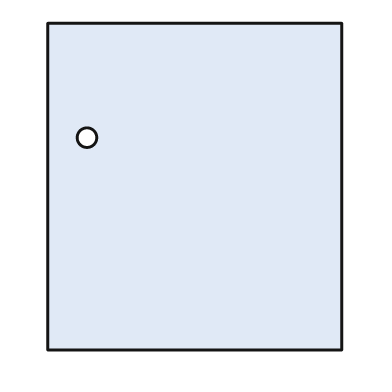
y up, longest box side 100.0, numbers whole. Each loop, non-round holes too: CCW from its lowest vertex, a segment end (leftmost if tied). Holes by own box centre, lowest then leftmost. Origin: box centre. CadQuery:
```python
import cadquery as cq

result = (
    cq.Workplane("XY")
    .moveTo(-45.0, -50.0)
    .lineTo(45.0, -50.0)
    .lineTo(45.0, 50.0)
    .lineTo(-45.0, 50.0)
    .close()
    .moveTo(-33.0, 15.0)
    .circle(3.0)
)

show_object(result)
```